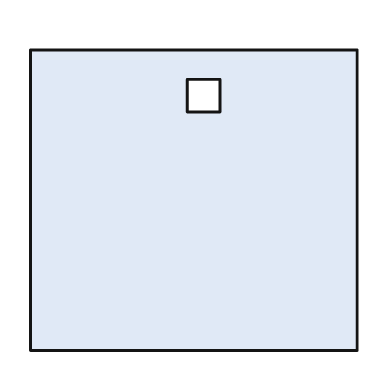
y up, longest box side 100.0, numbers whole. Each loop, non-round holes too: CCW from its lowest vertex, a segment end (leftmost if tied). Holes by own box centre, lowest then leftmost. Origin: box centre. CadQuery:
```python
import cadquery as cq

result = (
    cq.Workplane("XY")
    .moveTo(-50.0, -46.0)
    .lineTo(50.0, -46.0)
    .lineTo(50.0, 46.0)
    .lineTo(-50.0, 46.0)
    .close()
    .moveTo(-2.0, 27.0)
    .lineTo(8.0, 27.0)
    .lineTo(8.0, 37.0)
    .lineTo(-2.0, 37.0)
    .close()
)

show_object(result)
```